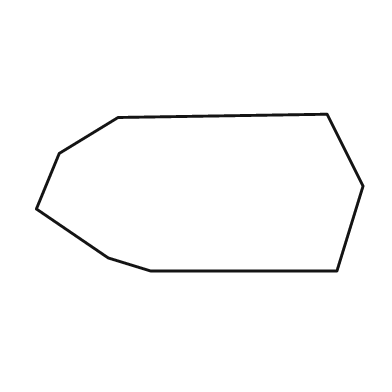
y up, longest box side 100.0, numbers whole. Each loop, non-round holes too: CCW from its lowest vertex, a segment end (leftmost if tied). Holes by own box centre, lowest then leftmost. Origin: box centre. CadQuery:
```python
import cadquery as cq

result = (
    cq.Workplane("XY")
    .moveTo(-15.0, -24.0)
    .lineTo(42.0, -24.0)
    .lineTo(50.0, 2.0)
    .lineTo(39.0, 24.0)
    .lineTo(-25.0, 23.0)
    .lineTo(-43.0, 12.0)
    .lineTo(-50.0, -5.0)
    .lineTo(-28.0, -20.0)
    .close()
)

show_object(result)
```